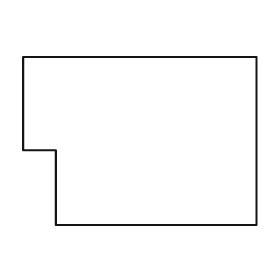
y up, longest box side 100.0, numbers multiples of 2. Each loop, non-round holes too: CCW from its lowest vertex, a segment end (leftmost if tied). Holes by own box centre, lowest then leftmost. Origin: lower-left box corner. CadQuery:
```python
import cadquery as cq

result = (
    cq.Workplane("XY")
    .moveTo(14.0, 0.0)
    .lineTo(100.0, 0.0)
    .lineTo(100.0, 72.0)
    .lineTo(0.0, 72.0)
    .lineTo(0.0, 32.0)
    .lineTo(14.0, 32.0)
    .close()
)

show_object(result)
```